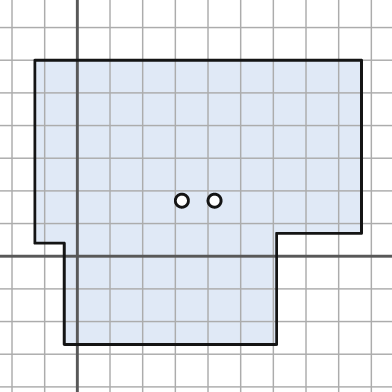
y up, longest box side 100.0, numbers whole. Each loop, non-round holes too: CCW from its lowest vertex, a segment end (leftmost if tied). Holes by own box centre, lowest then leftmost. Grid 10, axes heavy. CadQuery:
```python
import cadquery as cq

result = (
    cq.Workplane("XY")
    .moveTo(-4.0, -27.0)
    .lineTo(61.0, -27.0)
    .lineTo(61.0, 7.0)
    .lineTo(87.0, 7.0)
    .lineTo(87.0, 60.0)
    .lineTo(-13.0, 60.0)
    .lineTo(-13.0, 4.0)
    .lineTo(-4.0, 4.0)
    .close()
    .moveTo(32.0, 17.0)
    .circle(2.0)
    .moveTo(42.0, 17.0)
    .circle(2.0)
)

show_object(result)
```